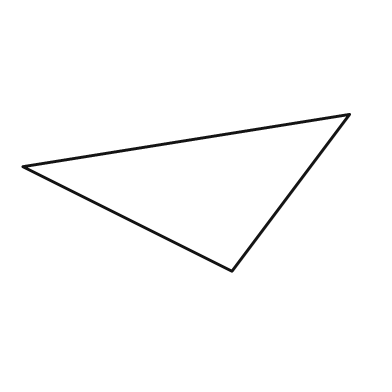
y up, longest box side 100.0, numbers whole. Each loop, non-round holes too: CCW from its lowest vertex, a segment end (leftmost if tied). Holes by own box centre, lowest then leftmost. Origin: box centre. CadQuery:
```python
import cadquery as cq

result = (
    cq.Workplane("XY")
    .moveTo(14.0, -24.0)
    .lineTo(50.0, 24.0)
    .lineTo(-50.0, 8.0)
    .close()
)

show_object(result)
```